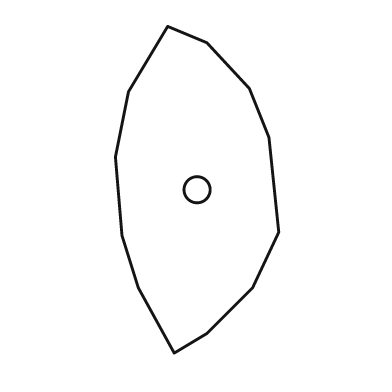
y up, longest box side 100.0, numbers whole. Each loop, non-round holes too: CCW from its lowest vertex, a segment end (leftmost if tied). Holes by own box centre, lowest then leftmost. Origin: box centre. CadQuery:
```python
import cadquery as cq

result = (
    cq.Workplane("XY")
    .moveTo(-7.0, -50.0)
    .lineTo(3.0, -44.0)
    .lineTo(17.0, -30.0)
    .lineTo(25.0, -13.0)
    .lineTo(22.0, 16.0)
    .lineTo(16.0, 31.0)
    .lineTo(3.0, 45.0)
    .lineTo(-9.0, 50.0)
    .lineTo(-21.0, 30.0)
    .lineTo(-25.0, 10.0)
    .lineTo(-23.0, -14.0)
    .lineTo(-18.0, -30.0)
    .close()
    .moveTo(0.0, 0.0)
    .circle(4.0)
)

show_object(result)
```